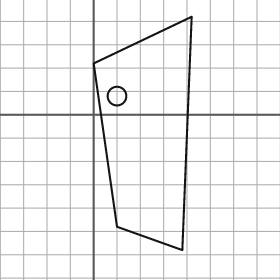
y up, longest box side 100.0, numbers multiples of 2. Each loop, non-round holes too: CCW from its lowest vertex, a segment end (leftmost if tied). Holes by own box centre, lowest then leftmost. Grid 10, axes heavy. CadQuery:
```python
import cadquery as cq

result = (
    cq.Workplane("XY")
    .moveTo(38.0, -58.0)
    .lineTo(42.0, 42.0)
    .lineTo(0.0, 22.0)
    .lineTo(10.0, -48.0)
    .close()
    .moveTo(10.0, 8.0)
    .circle(4.0)
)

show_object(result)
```